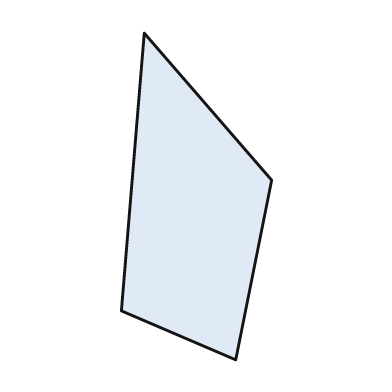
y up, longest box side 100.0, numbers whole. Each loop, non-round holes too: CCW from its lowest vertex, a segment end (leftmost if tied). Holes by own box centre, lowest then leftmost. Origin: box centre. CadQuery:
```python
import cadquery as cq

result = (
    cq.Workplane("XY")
    .moveTo(12.0, -50.0)
    .lineTo(23.0, 5.0)
    .lineTo(-16.0, 50.0)
    .lineTo(-23.0, -35.0)
    .close()
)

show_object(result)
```